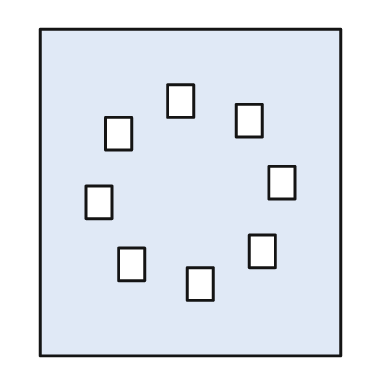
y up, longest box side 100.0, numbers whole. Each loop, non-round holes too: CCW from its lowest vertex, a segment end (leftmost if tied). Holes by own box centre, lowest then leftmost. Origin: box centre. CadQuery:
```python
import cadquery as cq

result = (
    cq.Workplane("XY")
    .moveTo(-46.0, -50.0)
    .lineTo(46.0, -50.0)
    .lineTo(46.0, 50.0)
    .lineTo(-46.0, 50.0)
    .close()
    .moveTo(-1.0, -33.0)
    .lineTo(7.0, -33.0)
    .lineTo(7.0, -23.0)
    .lineTo(-1.0, -23.0)
    .close()
    .moveTo(-22.0, -27.0)
    .lineTo(-14.0, -27.0)
    .lineTo(-14.0, -17.0)
    .lineTo(-22.0, -17.0)
    .close()
    .moveTo(18.0, -23.0)
    .lineTo(26.0, -23.0)
    .lineTo(26.0, -13.0)
    .lineTo(18.0, -13.0)
    .close()
    .moveTo(-32.0, -8.0)
    .lineTo(-24.0, -8.0)
    .lineTo(-24.0, 2.0)
    .lineTo(-32.0, 2.0)
    .close()
    .moveTo(24.0, -2.0)
    .lineTo(32.0, -2.0)
    .lineTo(32.0, 8.0)
    .lineTo(24.0, 8.0)
    .close()
    .moveTo(-26.0, 13.0)
    .lineTo(-18.0, 13.0)
    .lineTo(-18.0, 23.0)
    .lineTo(-26.0, 23.0)
    .close()
    .moveTo(14.0, 17.0)
    .lineTo(22.0, 17.0)
    .lineTo(22.0, 27.0)
    .lineTo(14.0, 27.0)
    .close()
    .moveTo(-7.0, 23.0)
    .lineTo(1.0, 23.0)
    .lineTo(1.0, 33.0)
    .lineTo(-7.0, 33.0)
    .close()
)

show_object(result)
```